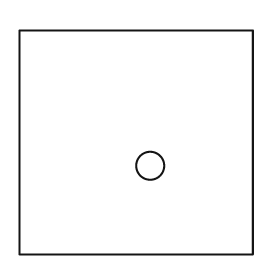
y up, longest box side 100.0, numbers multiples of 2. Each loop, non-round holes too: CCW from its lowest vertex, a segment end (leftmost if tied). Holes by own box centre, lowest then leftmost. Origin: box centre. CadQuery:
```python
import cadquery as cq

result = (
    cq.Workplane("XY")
    .moveTo(-50.0, -48.0)
    .lineTo(50.0, -48.0)
    .lineTo(50.0, 48.0)
    .lineTo(-50.0, 48.0)
    .close()
    .moveTo(6.0, -10.0)
    .circle(6.0)
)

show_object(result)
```